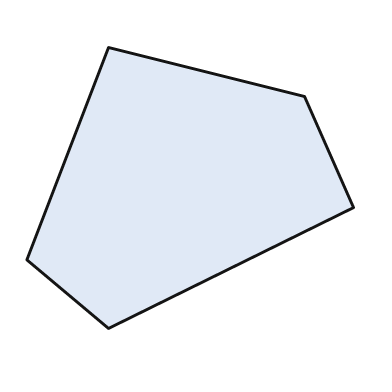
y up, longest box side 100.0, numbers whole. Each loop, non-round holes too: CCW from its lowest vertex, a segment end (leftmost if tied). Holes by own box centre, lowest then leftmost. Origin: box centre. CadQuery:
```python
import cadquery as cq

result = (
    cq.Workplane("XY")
    .moveTo(-25.0, -43.0)
    .lineTo(50.0, -6.0)
    .lineTo(35.0, 28.0)
    .lineTo(-25.0, 43.0)
    .lineTo(-50.0, -22.0)
    .close()
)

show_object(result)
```